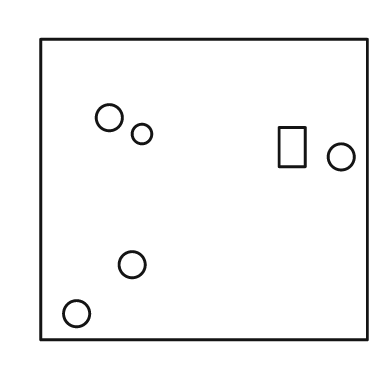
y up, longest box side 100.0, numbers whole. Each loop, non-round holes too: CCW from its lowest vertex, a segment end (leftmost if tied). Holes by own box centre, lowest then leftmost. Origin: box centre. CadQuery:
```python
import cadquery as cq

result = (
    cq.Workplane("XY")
    .moveTo(-50.0, -46.0)
    .lineTo(50.0, -46.0)
    .lineTo(50.0, 46.0)
    .lineTo(-50.0, 46.0)
    .close()
    .moveTo(-39.0, -38.0)
    .circle(4.0)
    .moveTo(-22.0, -23.0)
    .circle(4.0)
    .moveTo(42.0, 10.0)
    .circle(4.0)
    .moveTo(23.0, 7.0)
    .lineTo(31.0, 7.0)
    .lineTo(31.0, 19.0)
    .lineTo(23.0, 19.0)
    .close()
    .moveTo(-19.0, 17.0)
    .circle(3.0)
    .moveTo(-29.0, 22.0)
    .circle(4.0)
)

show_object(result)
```